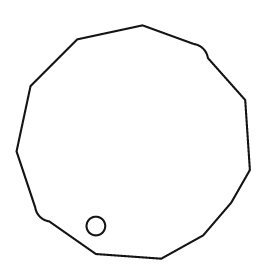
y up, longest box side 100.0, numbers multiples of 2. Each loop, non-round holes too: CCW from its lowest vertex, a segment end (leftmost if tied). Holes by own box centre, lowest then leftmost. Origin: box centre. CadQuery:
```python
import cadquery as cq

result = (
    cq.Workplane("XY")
    .moveTo(12.0, -50.0)
    .lineTo(30.0, -40.0)
    .lineTo(42.0, -26.0)
    .lineTo(50.0, -12.0)
    .lineTo(48.0, 18.0)
    .lineTo(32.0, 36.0)
    .threePointArc((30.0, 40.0), (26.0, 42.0))
    .lineTo(4.0, 50.0)
    .lineTo(-24.0, 44.0)
    .lineTo(-44.0, 24.0)
    .lineTo(-50.0, -4.0)
    .lineTo(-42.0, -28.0)
    .threePointArc((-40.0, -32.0), (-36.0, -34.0))
    .lineTo(-16.0, -48.0)
    .close()
    .moveTo(-16.0, -36.0)
    .circle(4.0)
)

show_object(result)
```